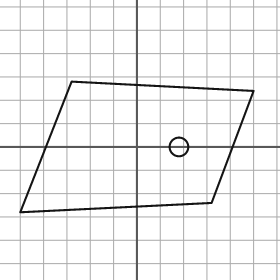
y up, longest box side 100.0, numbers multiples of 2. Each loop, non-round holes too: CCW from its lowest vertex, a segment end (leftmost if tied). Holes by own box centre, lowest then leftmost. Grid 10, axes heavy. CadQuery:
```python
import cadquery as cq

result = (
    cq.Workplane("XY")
    .moveTo(-50.0, -28.0)
    .lineTo(32.0, -24.0)
    .lineTo(50.0, 24.0)
    .lineTo(-28.0, 28.0)
    .close()
    .moveTo(18.0, 0.0)
    .circle(4.0)
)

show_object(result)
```